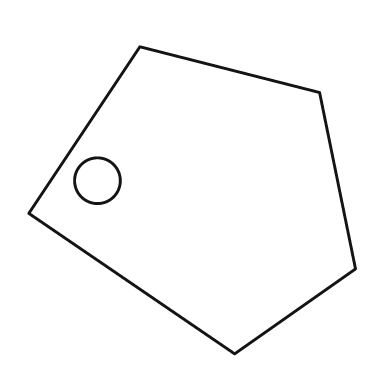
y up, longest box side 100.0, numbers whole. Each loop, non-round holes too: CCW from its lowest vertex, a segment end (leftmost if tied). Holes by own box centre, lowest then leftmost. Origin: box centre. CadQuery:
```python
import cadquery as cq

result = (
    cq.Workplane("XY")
    .moveTo(13.0, -47.0)
    .lineTo(50.0, -21.0)
    .lineTo(39.0, 33.0)
    .lineTo(-16.0, 47.0)
    .lineTo(-50.0, -4.0)
    .close()
    .moveTo(-29.0, 6.0)
    .circle(7.0)
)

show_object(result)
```